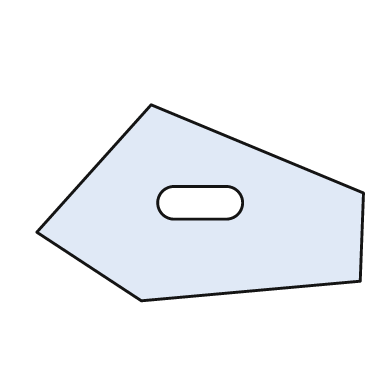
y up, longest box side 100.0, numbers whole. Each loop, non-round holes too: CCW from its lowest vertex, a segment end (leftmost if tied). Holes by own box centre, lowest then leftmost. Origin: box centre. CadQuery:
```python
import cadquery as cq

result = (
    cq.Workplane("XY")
    .moveTo(-18.0, -30.0)
    .lineTo(49.0, -24.0)
    .lineTo(50.0, 3.0)
    .lineTo(-15.0, 30.0)
    .lineTo(-50.0, -9.0)
    .close()
    .moveTo(-8.0, -5.0)
    .lineTo(8.0, -5.0)
    .threePointArc((13.0, 0.0), (8.0, 5.0))
    .lineTo(-8.0, 5.0)
    .threePointArc((-13.0, 0.0), (-8.0, -5.0))
    .close()
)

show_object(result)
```